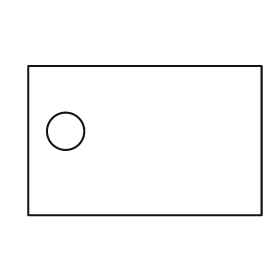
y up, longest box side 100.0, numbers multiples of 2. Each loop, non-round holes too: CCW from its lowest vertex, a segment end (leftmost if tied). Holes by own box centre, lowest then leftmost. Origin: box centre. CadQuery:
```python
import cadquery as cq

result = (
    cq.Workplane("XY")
    .moveTo(-50.0, -32.0)
    .lineTo(50.0, -32.0)
    .lineTo(50.0, 32.0)
    .lineTo(-50.0, 32.0)
    .close()
    .moveTo(-34.0, 4.0)
    .circle(8.0)
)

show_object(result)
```